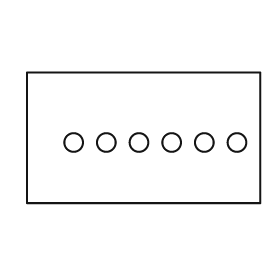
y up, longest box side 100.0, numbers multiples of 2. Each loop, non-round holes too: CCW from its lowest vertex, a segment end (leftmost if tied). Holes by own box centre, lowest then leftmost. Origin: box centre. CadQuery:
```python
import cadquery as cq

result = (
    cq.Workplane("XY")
    .moveTo(-50.0, -28.0)
    .lineTo(50.0, -28.0)
    .lineTo(50.0, 28.0)
    .lineTo(-50.0, 28.0)
    .close()
    .moveTo(-30.0, -2.0)
    .circle(4.0)
    .moveTo(-16.0, -2.0)
    .circle(4.0)
    .moveTo(-2.0, -2.0)
    .circle(4.0)
    .moveTo(12.0, -2.0)
    .circle(4.0)
    .moveTo(26.0, -2.0)
    .circle(4.0)
    .moveTo(40.0, -2.0)
    .circle(4.0)
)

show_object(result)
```